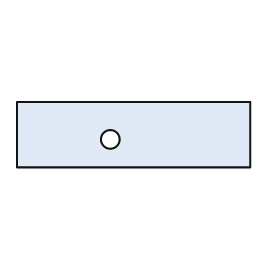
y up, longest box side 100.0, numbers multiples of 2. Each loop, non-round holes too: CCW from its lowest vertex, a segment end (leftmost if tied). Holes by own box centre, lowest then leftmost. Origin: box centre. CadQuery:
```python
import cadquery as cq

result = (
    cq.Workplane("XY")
    .moveTo(-50.0, -14.0)
    .lineTo(50.0, -14.0)
    .lineTo(50.0, 14.0)
    .lineTo(-50.0, 14.0)
    .close()
    .moveTo(-10.0, -2.0)
    .circle(4.0)
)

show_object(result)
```